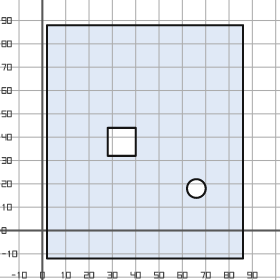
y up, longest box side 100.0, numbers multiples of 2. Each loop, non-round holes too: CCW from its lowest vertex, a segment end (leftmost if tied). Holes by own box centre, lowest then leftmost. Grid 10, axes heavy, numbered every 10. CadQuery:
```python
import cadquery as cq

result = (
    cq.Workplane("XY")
    .moveTo(2.0, -12.0)
    .lineTo(86.0, -12.0)
    .lineTo(86.0, 88.0)
    .lineTo(2.0, 88.0)
    .close()
    .moveTo(66.0, 18.0)
    .circle(4.0)
    .moveTo(28.0, 32.0)
    .lineTo(40.0, 32.0)
    .lineTo(40.0, 44.0)
    .lineTo(28.0, 44.0)
    .close()
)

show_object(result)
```